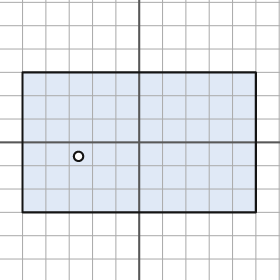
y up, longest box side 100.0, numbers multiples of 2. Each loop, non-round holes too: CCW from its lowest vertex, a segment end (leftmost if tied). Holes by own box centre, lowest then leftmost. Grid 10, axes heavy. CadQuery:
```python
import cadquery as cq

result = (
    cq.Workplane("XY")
    .moveTo(-50.0, -30.0)
    .lineTo(50.0, -30.0)
    .lineTo(50.0, 30.0)
    .lineTo(-50.0, 30.0)
    .close()
    .moveTo(-26.0, -6.0)
    .circle(2.0)
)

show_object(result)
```